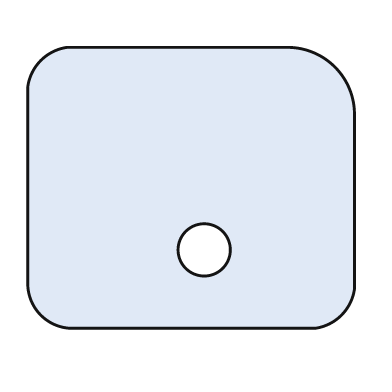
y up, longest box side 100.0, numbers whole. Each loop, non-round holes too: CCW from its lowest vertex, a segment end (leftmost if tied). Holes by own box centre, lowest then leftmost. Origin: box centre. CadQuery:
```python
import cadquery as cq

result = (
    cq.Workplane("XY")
    .moveTo(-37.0, -43.0)
    .lineTo(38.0, -43.0)
    .threePointArc((46.0, -39.0), (50.0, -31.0))
    .lineTo(50.0, 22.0)
    .threePointArc((44.0, 37.0), (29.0, 43.0))
    .lineTo(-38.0, 43.0)
    .threePointArc((-46.0, 39.0), (-50.0, 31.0))
    .lineTo(-50.0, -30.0)
    .threePointArc((-46.0, -39.0), (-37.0, -43.0))
    .close()
    .moveTo(4.0, -19.0)
    .circle(8.0)
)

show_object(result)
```